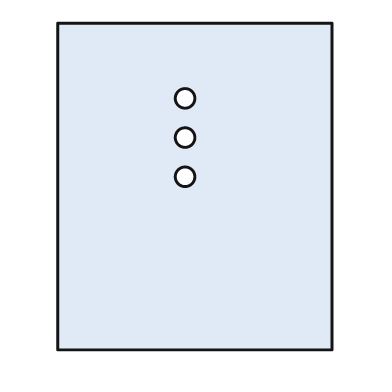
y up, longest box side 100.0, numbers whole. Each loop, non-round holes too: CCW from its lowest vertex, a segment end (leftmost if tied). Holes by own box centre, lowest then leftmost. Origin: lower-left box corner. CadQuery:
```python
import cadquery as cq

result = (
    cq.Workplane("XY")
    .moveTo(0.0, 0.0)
    .lineTo(84.0, 0.0)
    .lineTo(84.0, 100.0)
    .lineTo(0.0, 100.0)
    .close()
    .moveTo(39.0, 53.0)
    .circle(3.0)
    .moveTo(39.0, 65.0)
    .circle(3.0)
    .moveTo(39.0, 77.0)
    .circle(3.0)
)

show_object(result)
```